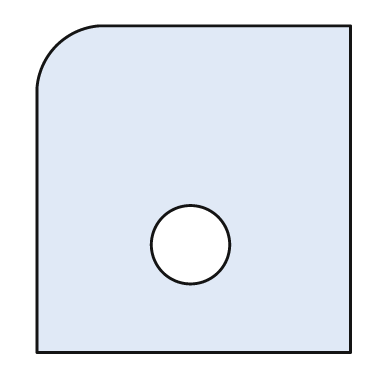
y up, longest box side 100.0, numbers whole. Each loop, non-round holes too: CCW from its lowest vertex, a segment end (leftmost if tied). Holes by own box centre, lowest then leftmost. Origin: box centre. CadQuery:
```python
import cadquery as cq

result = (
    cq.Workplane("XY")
    .moveTo(-48.0, -50.0)
    .lineTo(48.0, -50.0)
    .lineTo(48.0, 50.0)
    .lineTo(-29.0, 50.0)
    .threePointArc((-42.0, 44.0), (-48.0, 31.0))
    .close()
    .moveTo(-1.0, -17.0)
    .circle(12.0)
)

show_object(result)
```